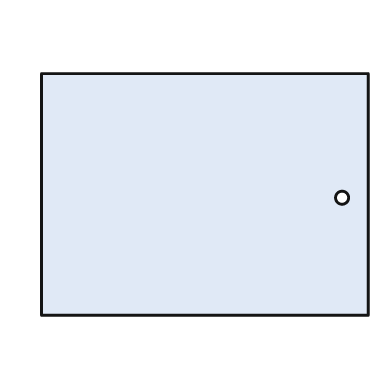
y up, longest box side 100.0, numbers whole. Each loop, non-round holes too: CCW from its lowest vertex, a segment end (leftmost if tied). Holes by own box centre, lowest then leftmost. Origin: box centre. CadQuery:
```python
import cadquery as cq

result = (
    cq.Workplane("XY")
    .moveTo(-50.0, -37.0)
    .lineTo(50.0, -37.0)
    .lineTo(50.0, 37.0)
    .lineTo(-50.0, 37.0)
    .close()
    .moveTo(42.0, -1.0)
    .circle(2.0)
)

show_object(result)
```